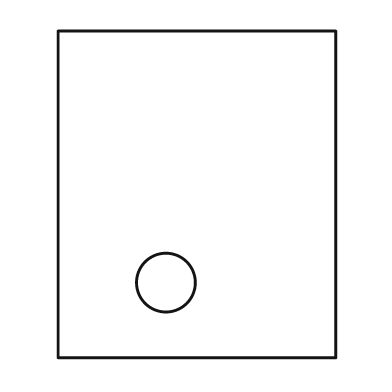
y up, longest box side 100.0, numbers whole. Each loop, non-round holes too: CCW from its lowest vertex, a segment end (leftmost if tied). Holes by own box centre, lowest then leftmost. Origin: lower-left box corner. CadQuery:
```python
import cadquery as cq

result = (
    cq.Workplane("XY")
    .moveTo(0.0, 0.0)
    .lineTo(85.0, 0.0)
    .lineTo(85.0, 100.0)
    .lineTo(0.0, 100.0)
    .close()
    .moveTo(33.0, 23.0)
    .circle(9.0)
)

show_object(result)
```